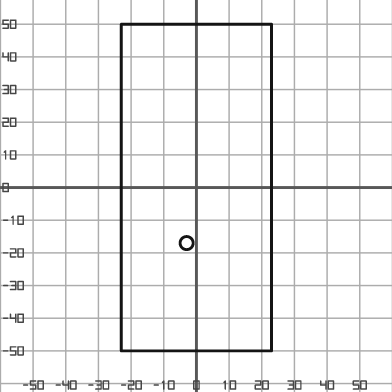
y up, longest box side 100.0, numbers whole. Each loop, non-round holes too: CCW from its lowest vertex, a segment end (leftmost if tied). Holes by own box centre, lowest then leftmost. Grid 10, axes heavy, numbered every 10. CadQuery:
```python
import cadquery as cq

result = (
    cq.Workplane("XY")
    .moveTo(-23.0, -50.0)
    .lineTo(23.0, -50.0)
    .lineTo(23.0, 50.0)
    .lineTo(-23.0, 50.0)
    .close()
    .moveTo(-3.0, -17.0)
    .circle(2.0)
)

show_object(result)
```